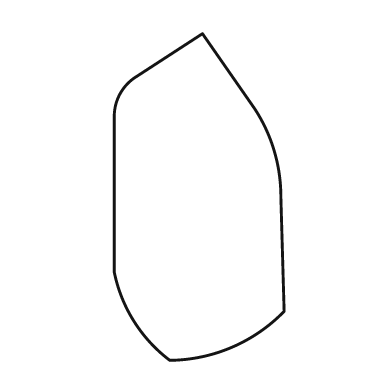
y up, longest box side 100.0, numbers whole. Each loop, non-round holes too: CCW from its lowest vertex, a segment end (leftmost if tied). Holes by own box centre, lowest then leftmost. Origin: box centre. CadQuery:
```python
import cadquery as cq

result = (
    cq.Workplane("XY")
    .moveTo(-9.0, -50.0)
    .threePointArc((10.0, -46.0), (26.0, -35.0))
    .lineTo(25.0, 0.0)
    .threePointArc((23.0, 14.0), (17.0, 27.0))
    .lineTo(1.0, 50.0)
    .lineTo(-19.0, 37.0)
    .threePointArc((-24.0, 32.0), (-26.0, 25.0))
    .lineTo(-26.0, -23.0)
    .threePointArc((-20.0, -38.0), (-9.0, -50.0))
    .close()
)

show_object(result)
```